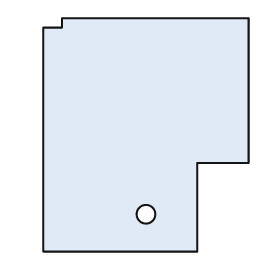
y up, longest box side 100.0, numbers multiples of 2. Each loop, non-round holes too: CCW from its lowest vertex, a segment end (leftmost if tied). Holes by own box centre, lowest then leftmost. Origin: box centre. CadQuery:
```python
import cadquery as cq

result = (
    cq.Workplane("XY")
    .moveTo(-44.0, -50.0)
    .lineTo(22.0, -50.0)
    .lineTo(22.0, -12.0)
    .lineTo(44.0, -12.0)
    .lineTo(44.0, 50.0)
    .lineTo(-36.0, 50.0)
    .lineTo(-36.0, 46.0)
    .lineTo(-44.0, 46.0)
    .close()
    .moveTo(0.0, -34.0)
    .circle(4.0)
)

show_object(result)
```